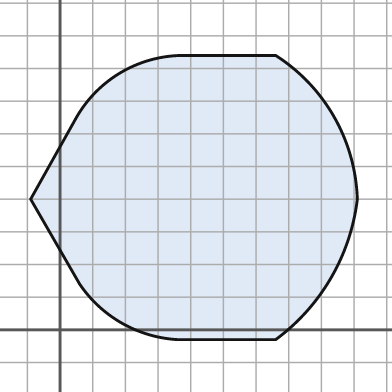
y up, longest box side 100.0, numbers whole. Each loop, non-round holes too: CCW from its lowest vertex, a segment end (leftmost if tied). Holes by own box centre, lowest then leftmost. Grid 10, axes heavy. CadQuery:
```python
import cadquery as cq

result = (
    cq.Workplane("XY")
    .moveTo(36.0, -3.0)
    .lineTo(66.0, -3.0)
    .threePointArc((83.0, 16.0), (91.0, 40.0))
    .threePointArc((84.0, 65.0), (66.0, 84.0))
    .lineTo(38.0, 84.0)
    .threePointArc((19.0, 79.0), (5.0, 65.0))
    .lineTo(-9.0, 40.0)
    .lineTo(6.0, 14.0)
    .threePointArc((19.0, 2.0), (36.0, -3.0))
    .close()
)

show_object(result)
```